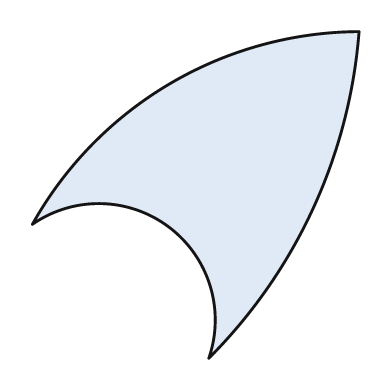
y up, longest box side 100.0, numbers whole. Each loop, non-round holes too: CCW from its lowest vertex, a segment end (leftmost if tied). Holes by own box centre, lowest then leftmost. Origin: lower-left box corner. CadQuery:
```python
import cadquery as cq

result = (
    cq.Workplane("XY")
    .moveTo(54.0, 0.0)
    .threePointArc((86.0, 46.0), (100.0, 100.0))
    .threePointArc((42.0, 84.0), (0.0, 41.0))
    .threePointArc((42.0, 40.0), (54.0, 0.0))
    .close()
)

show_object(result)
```